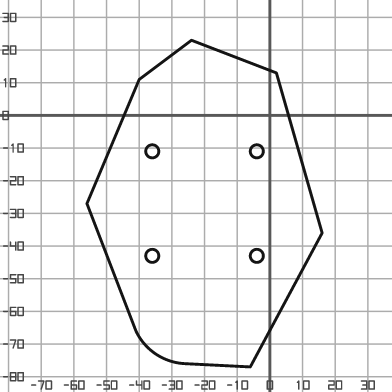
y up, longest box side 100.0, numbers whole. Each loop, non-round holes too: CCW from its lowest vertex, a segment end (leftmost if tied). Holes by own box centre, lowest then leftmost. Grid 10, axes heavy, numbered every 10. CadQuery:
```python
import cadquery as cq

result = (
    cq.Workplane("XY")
    .moveTo(-6.0, -77.0)
    .lineTo(16.0, -36.0)
    .lineTo(2.0, 13.0)
    .lineTo(-24.0, 23.0)
    .lineTo(-40.0, 11.0)
    .lineTo(-56.0, -27.0)
    .lineTo(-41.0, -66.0)
    .threePointArc((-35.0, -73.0), (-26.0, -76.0))
    .close()
    .moveTo(-36.0, -43.0)
    .circle(2.0)
    .moveTo(-4.0, -43.0)
    .circle(2.0)
    .moveTo(-36.0, -11.0)
    .circle(2.0)
    .moveTo(-4.0, -11.0)
    .circle(2.0)
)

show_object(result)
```